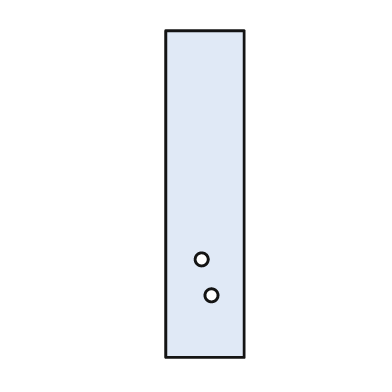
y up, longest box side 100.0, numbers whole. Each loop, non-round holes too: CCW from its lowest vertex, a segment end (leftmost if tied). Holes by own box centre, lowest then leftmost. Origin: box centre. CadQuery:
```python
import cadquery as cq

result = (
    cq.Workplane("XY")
    .moveTo(-12.0, -50.0)
    .lineTo(12.0, -50.0)
    .lineTo(12.0, 50.0)
    .lineTo(-12.0, 50.0)
    .close()
    .moveTo(2.0, -31.0)
    .circle(2.0)
    .moveTo(-1.0, -20.0)
    .circle(2.0)
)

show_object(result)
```